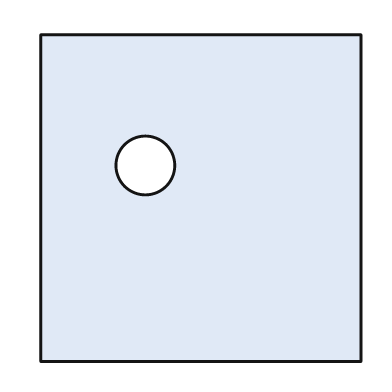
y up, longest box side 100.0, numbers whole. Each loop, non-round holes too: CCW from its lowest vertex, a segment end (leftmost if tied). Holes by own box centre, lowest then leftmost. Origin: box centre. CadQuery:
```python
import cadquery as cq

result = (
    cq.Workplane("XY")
    .moveTo(-49.0, -50.0)
    .lineTo(49.0, -50.0)
    .lineTo(49.0, 50.0)
    .lineTo(-49.0, 50.0)
    .close()
    .moveTo(-17.0, 10.0)
    .circle(9.0)
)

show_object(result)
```